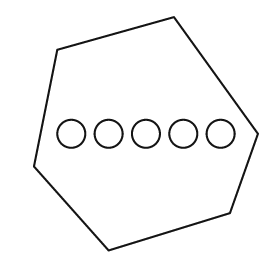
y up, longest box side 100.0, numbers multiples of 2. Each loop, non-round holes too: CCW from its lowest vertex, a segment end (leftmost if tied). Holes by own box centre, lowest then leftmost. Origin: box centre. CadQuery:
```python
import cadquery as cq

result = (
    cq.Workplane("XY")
    .moveTo(-16.0, -50.0)
    .lineTo(36.0, -34.0)
    .lineTo(48.0, 0.0)
    .lineTo(12.0, 50.0)
    .lineTo(-38.0, 36.0)
    .lineTo(-48.0, -14.0)
    .close()
    .moveTo(-32.0, 0.0)
    .circle(6.0)
    .moveTo(-16.0, 0.0)
    .circle(6.0)
    .moveTo(0.0, 0.0)
    .circle(6.0)
    .moveTo(16.0, 0.0)
    .circle(6.0)
    .moveTo(32.0, 0.0)
    .circle(6.0)
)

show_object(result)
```